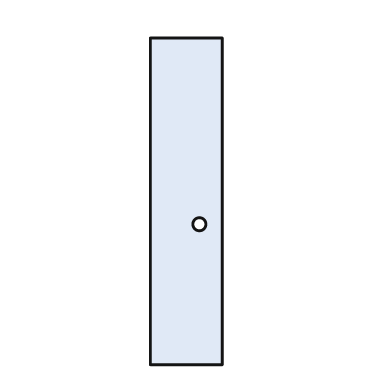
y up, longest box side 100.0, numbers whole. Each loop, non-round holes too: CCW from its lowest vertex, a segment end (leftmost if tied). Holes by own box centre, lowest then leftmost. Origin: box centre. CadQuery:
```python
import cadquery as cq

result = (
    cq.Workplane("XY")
    .moveTo(-11.0, -50.0)
    .lineTo(11.0, -50.0)
    .lineTo(11.0, 50.0)
    .lineTo(-11.0, 50.0)
    .close()
    .moveTo(4.0, -7.0)
    .circle(2.0)
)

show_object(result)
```